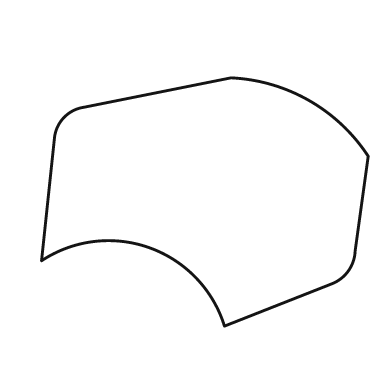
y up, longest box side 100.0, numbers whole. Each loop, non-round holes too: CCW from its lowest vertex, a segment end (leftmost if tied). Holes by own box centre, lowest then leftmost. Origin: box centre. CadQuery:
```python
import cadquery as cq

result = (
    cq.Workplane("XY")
    .moveTo(6.0, -38.0)
    .lineTo(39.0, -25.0)
    .threePointArc((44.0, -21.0), (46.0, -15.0))
    .lineTo(50.0, 14.0)
    .threePointArc((32.0, 31.0), (8.0, 38.0))
    .lineTo(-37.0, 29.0)
    .threePointArc((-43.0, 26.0), (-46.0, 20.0))
    .lineTo(-50.0, -18.0)
    .threePointArc((-17.0, -14.0), (6.0, -38.0))
    .close()
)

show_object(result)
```